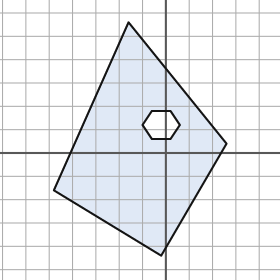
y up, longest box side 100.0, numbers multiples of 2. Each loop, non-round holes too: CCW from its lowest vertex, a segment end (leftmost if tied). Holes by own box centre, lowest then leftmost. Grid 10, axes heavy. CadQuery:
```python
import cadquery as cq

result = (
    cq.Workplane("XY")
    .moveTo(-2.0, -44.0)
    .lineTo(26.0, 4.0)
    .lineTo(-16.0, 56.0)
    .lineTo(-48.0, -16.0)
    .close()
    .moveTo(-6.0, 6.0)
    .lineTo(2.0, 6.0)
    .lineTo(6.0, 12.0)
    .lineTo(2.0, 18.0)
    .lineTo(-6.0, 18.0)
    .lineTo(-10.0, 12.0)
    .close()
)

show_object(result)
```